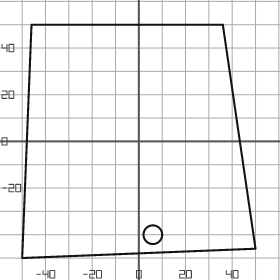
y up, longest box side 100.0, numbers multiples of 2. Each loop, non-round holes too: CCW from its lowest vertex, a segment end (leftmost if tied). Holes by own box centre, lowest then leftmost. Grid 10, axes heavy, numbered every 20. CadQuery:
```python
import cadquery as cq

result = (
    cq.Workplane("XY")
    .moveTo(-50.0, -50.0)
    .lineTo(50.0, -46.0)
    .lineTo(36.0, 50.0)
    .lineTo(-46.0, 50.0)
    .close()
    .moveTo(6.0, -40.0)
    .circle(4.0)
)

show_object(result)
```